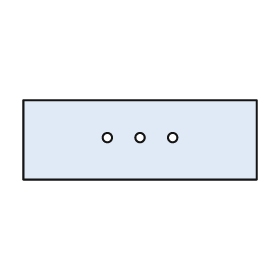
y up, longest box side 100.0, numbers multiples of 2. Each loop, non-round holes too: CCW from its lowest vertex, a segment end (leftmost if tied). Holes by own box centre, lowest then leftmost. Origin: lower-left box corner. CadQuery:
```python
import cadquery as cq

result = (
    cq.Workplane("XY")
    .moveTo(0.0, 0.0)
    .lineTo(100.0, 0.0)
    .lineTo(100.0, 34.0)
    .lineTo(0.0, 34.0)
    .close()
    .moveTo(36.0, 18.0)
    .circle(2.0)
    .moveTo(50.0, 18.0)
    .circle(2.0)
    .moveTo(64.0, 18.0)
    .circle(2.0)
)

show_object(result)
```